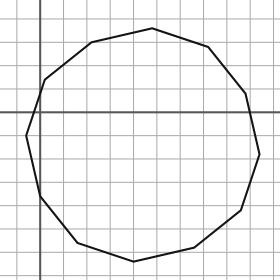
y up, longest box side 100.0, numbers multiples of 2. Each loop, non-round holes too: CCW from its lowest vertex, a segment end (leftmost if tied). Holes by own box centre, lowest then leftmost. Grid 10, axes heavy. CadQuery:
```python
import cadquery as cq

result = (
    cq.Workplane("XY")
    .moveTo(40.0, -64.0)
    .lineTo(66.0, -58.0)
    .lineTo(86.0, -42.0)
    .lineTo(94.0, -18.0)
    .lineTo(88.0, 8.0)
    .lineTo(72.0, 28.0)
    .lineTo(48.0, 36.0)
    .lineTo(22.0, 30.0)
    .lineTo(2.0, 14.0)
    .lineTo(-6.0, -10.0)
    .lineTo(0.0, -36.0)
    .lineTo(16.0, -56.0)
    .close()
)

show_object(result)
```